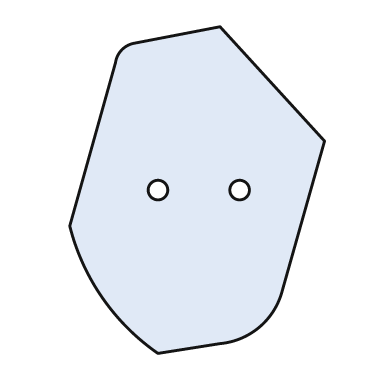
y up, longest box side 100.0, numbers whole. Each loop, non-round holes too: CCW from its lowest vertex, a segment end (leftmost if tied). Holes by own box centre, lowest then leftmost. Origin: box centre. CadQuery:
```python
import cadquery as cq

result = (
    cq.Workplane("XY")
    .moveTo(-12.0, -50.0)
    .lineTo(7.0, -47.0)
    .threePointArc((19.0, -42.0), (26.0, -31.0))
    .lineTo(39.0, 15.0)
    .lineTo(7.0, 50.0)
    .lineTo(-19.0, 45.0)
    .threePointArc((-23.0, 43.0), (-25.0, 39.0))
    .lineTo(-39.0, -11.0)
    .threePointArc((-29.0, -33.0), (-12.0, -50.0))
    .close()
    .moveTo(-12.0, 0.0)
    .circle(3.0)
    .moveTo(13.0, 0.0)
    .circle(3.0)
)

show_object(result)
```